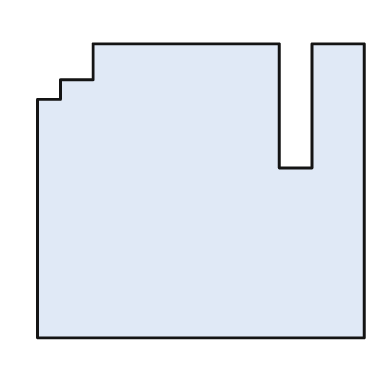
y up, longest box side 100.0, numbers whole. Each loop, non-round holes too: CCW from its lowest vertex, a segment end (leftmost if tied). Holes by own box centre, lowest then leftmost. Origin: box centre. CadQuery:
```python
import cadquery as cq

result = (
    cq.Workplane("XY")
    .moveTo(-50.0, -45.0)
    .lineTo(50.0, -45.0)
    .lineTo(50.0, 45.0)
    .lineTo(34.0, 45.0)
    .lineTo(34.0, 7.0)
    .lineTo(24.0, 7.0)
    .lineTo(24.0, 45.0)
    .lineTo(-33.0, 45.0)
    .lineTo(-33.0, 34.0)
    .lineTo(-43.0, 34.0)
    .lineTo(-43.0, 28.0)
    .lineTo(-50.0, 28.0)
    .close()
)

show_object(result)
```